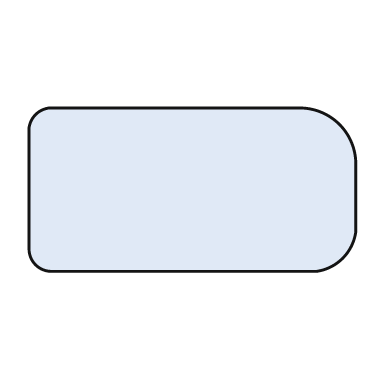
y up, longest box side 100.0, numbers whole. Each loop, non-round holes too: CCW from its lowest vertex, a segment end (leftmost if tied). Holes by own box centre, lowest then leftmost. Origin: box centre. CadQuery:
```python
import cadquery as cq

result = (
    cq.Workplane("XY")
    .moveTo(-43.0, -25.0)
    .lineTo(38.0, -25.0)
    .threePointArc((46.0, -21.0), (50.0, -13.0))
    .lineTo(50.0, 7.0)
    .threePointArc((45.0, 20.0), (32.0, 25.0))
    .lineTo(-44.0, 25.0)
    .threePointArc((-48.0, 23.0), (-50.0, 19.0))
    .lineTo(-50.0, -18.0)
    .threePointArc((-48.0, -23.0), (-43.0, -25.0))
    .close()
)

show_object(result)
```